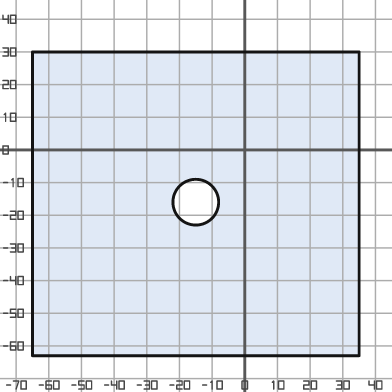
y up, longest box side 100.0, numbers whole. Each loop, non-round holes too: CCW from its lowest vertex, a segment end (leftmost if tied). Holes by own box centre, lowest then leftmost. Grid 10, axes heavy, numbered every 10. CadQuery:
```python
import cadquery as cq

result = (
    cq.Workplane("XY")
    .moveTo(-65.0, -63.0)
    .lineTo(35.0, -63.0)
    .lineTo(35.0, 30.0)
    .lineTo(-65.0, 30.0)
    .close()
    .moveTo(-15.0, -16.0)
    .circle(7.0)
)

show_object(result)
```